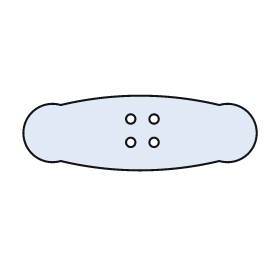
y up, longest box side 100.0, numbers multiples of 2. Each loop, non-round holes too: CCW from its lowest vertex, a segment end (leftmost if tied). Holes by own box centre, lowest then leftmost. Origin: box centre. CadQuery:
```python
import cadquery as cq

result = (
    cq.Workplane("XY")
    .moveTo(-34.0, -12.0)
    .threePointArc((0.0, -16.0), (34.0, -12.0))
    .threePointArc((50.0, 0.0), (34.0, 12.0))
    .threePointArc((0.0, 16.0), (-34.0, 12.0))
    .threePointArc((-50.0, 0.0), (-34.0, -12.0))
    .close()
    .moveTo(-4.0, -4.0)
    .circle(2.0)
    .moveTo(6.0, -4.0)
    .circle(2.0)
    .moveTo(-4.0, 6.0)
    .circle(2.0)
    .moveTo(6.0, 6.0)
    .circle(2.0)
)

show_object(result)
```